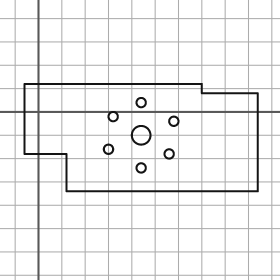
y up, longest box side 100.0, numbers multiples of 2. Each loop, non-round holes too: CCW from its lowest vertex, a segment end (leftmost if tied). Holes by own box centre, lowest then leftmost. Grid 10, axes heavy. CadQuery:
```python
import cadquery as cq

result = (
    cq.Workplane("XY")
    .moveTo(12.0, -34.0)
    .lineTo(94.0, -34.0)
    .lineTo(94.0, 8.0)
    .lineTo(70.0, 8.0)
    .lineTo(70.0, 12.0)
    .lineTo(-6.0, 12.0)
    .lineTo(-6.0, -18.0)
    .lineTo(12.0, -18.0)
    .close()
    .moveTo(44.0, -24.0)
    .circle(2.0)
    .moveTo(56.0, -18.0)
    .circle(2.0)
    .moveTo(30.0, -16.0)
    .circle(2.0)
    .moveTo(44.0, -10.0)
    .circle(4.0)
    .moveTo(58.0, -4.0)
    .circle(2.0)
    .moveTo(32.0, -2.0)
    .circle(2.0)
    .moveTo(44.0, 4.0)
    .circle(2.0)
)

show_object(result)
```